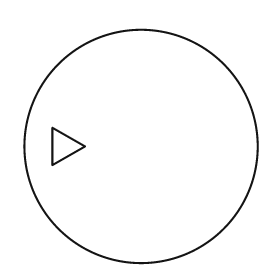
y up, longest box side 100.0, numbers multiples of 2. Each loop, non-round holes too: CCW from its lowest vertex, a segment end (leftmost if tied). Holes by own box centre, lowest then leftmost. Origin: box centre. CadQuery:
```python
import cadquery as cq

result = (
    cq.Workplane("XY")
    .moveTo(0.0, 0.0)
    .circle(50.0)
    .moveTo(-38.0, -8.0)
    .lineTo(-24.0, 0.0)
    .lineTo(-38.0, 8.0)
    .close()
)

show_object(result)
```